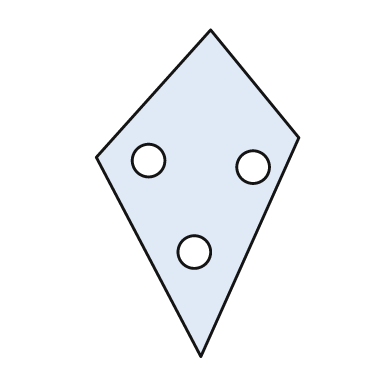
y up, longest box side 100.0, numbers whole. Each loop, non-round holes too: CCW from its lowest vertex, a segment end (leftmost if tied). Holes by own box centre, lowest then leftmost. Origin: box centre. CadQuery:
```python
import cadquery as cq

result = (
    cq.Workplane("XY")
    .moveTo(1.0, -50.0)
    .lineTo(31.0, 17.0)
    .lineTo(4.0, 50.0)
    .lineTo(-31.0, 11.0)
    .close()
    .moveTo(-1.0, -18.0)
    .circle(5.0)
    .moveTo(17.0, 8.0)
    .circle(5.0)
    .moveTo(-15.0, 10.0)
    .circle(5.0)
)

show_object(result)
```